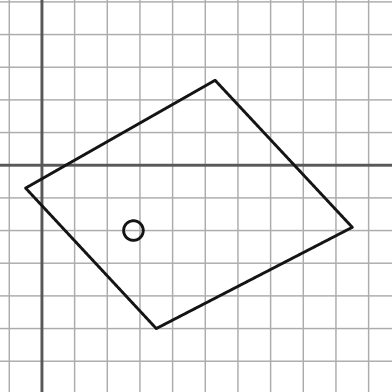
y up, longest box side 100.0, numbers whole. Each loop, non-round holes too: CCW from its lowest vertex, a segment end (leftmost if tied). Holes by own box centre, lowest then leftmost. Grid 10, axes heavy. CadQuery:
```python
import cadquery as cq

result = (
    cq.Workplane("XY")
    .moveTo(35.0, -50.0)
    .lineTo(95.0, -19.0)
    .lineTo(53.0, 26.0)
    .lineTo(-5.0, -7.0)
    .close()
    .moveTo(28.0, -20.0)
    .circle(3.0)
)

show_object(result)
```